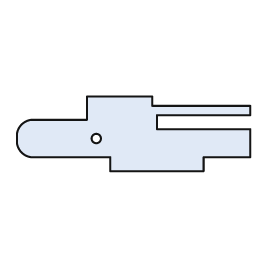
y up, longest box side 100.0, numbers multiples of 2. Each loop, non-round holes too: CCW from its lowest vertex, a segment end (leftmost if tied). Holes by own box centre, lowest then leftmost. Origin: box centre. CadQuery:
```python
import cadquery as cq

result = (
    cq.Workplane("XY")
    .moveTo(-10.0, -16.0)
    .lineTo(30.0, -16.0)
    .lineTo(30.0, -10.0)
    .lineTo(50.0, -10.0)
    .lineTo(50.0, 2.0)
    .lineTo(10.0, 2.0)
    .lineTo(10.0, 8.0)
    .lineTo(50.0, 8.0)
    .lineTo(50.0, 12.0)
    .lineTo(8.0, 12.0)
    .lineTo(8.0, 16.0)
    .lineTo(-20.0, 16.0)
    .lineTo(-20.0, 6.0)
    .lineTo(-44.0, 6.0)
    .threePointArc((-48.0, 4.0), (-50.0, 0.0))
    .lineTo(-50.0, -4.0)
    .threePointArc((-48.0, -8.0), (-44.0, -10.0))
    .lineTo(-10.0, -10.0)
    .close()
    .moveTo(-16.0, -2.0)
    .circle(2.0)
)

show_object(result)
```